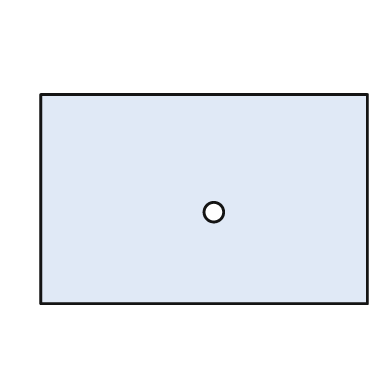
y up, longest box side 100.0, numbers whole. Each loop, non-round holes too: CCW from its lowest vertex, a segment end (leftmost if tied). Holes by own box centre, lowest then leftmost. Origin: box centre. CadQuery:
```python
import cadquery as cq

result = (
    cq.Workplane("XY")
    .moveTo(-50.0, -32.0)
    .lineTo(50.0, -32.0)
    .lineTo(50.0, 32.0)
    .lineTo(-50.0, 32.0)
    .close()
    .moveTo(3.0, -4.0)
    .circle(3.0)
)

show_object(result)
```